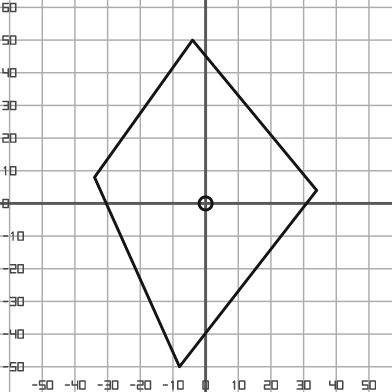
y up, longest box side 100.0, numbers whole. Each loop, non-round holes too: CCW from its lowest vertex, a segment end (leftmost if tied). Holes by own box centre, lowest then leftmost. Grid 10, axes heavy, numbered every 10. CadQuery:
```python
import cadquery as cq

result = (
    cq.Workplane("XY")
    .moveTo(-8.0, -50.0)
    .lineTo(34.0, 4.0)
    .lineTo(-4.0, 50.0)
    .lineTo(-34.0, 8.0)
    .close()
    .moveTo(0.0, 0.0)
    .circle(2.0)
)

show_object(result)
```